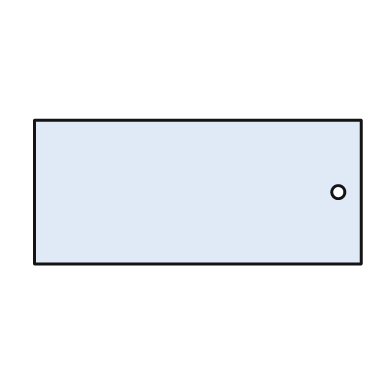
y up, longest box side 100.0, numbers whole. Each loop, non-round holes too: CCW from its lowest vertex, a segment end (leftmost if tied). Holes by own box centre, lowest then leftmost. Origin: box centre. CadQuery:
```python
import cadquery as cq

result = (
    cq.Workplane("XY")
    .moveTo(-50.0, -22.0)
    .lineTo(50.0, -22.0)
    .lineTo(50.0, 22.0)
    .lineTo(-50.0, 22.0)
    .close()
    .moveTo(43.0, 0.0)
    .circle(2.0)
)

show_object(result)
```